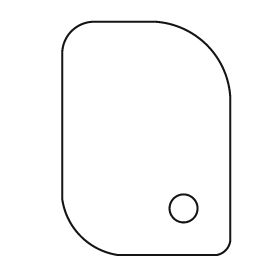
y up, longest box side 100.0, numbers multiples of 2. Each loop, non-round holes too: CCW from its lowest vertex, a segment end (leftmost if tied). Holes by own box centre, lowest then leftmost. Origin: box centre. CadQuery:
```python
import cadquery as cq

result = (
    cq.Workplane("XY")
    .moveTo(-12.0, -50.0)
    .lineTo(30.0, -50.0)
    .threePointArc((34.0, -48.0), (36.0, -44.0))
    .lineTo(36.0, 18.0)
    .threePointArc((26.0, 40.0), (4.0, 50.0))
    .lineTo(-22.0, 50.0)
    .threePointArc((-32.0, 46.0), (-36.0, 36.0))
    .lineTo(-36.0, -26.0)
    .threePointArc((-28.0, -42.0), (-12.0, -50.0))
    .close()
    .moveTo(16.0, -30.0)
    .circle(6.0)
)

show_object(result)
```